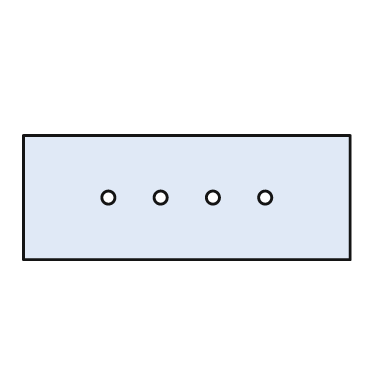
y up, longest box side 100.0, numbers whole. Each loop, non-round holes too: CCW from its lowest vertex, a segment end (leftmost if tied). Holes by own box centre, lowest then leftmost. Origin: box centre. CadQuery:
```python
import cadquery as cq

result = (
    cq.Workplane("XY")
    .moveTo(-50.0, -19.0)
    .lineTo(50.0, -19.0)
    .lineTo(50.0, 19.0)
    .lineTo(-50.0, 19.0)
    .close()
    .moveTo(-24.0, 0.0)
    .circle(2.0)
    .moveTo(-8.0, 0.0)
    .circle(2.0)
    .moveTo(8.0, 0.0)
    .circle(2.0)
    .moveTo(24.0, 0.0)
    .circle(2.0)
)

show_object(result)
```